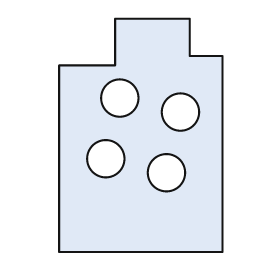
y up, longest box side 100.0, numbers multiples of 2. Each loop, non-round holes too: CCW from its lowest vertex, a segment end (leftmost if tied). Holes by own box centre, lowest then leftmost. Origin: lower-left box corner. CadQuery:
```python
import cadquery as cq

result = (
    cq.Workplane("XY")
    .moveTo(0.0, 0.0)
    .lineTo(70.0, 0.0)
    .lineTo(70.0, 84.0)
    .lineTo(56.0, 84.0)
    .lineTo(56.0, 100.0)
    .lineTo(24.0, 100.0)
    .lineTo(24.0, 80.0)
    .lineTo(0.0, 80.0)
    .close()
    .moveTo(46.0, 34.0)
    .circle(8.0)
    .moveTo(20.0, 40.0)
    .circle(8.0)
    .moveTo(52.0, 60.0)
    .circle(8.0)
    .moveTo(26.0, 66.0)
    .circle(8.0)
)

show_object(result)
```